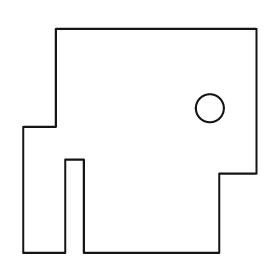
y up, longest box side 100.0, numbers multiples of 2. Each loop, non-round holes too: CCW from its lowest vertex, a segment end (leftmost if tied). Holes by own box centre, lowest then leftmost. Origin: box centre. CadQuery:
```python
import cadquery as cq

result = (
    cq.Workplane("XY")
    .moveTo(-50.0, -48.0)
    .lineTo(-32.0, -48.0)
    .lineTo(-32.0, -8.0)
    .lineTo(-24.0, -8.0)
    .lineTo(-24.0, -48.0)
    .lineTo(34.0, -48.0)
    .lineTo(34.0, -14.0)
    .lineTo(50.0, -14.0)
    .lineTo(50.0, 48.0)
    .lineTo(-36.0, 48.0)
    .lineTo(-36.0, 6.0)
    .lineTo(-50.0, 6.0)
    .close()
    .moveTo(30.0, 14.0)
    .circle(6.0)
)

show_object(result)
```